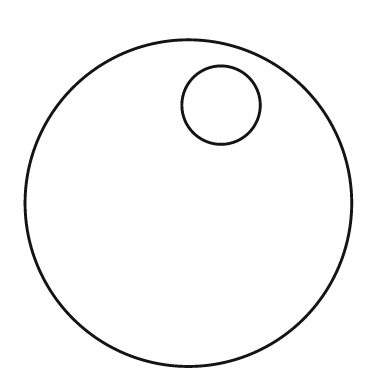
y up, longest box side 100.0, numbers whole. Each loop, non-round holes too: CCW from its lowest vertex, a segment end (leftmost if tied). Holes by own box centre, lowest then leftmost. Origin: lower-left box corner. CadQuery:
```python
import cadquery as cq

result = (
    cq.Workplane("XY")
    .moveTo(50.0, 50.0)
    .circle(50.0)
    .moveTo(60.0, 80.0)
    .circle(12.0)
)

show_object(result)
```